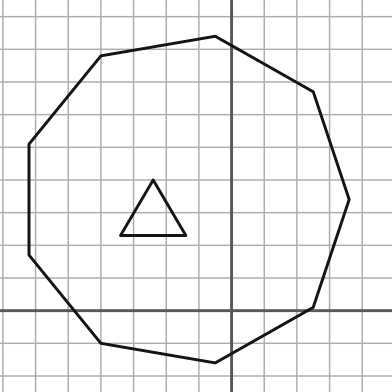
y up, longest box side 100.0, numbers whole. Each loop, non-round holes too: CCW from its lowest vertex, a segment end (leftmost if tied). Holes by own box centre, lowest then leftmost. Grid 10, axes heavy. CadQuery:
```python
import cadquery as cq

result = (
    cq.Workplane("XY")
    .moveTo(-5.0, -16.0)
    .lineTo(25.0, 1.0)
    .lineTo(36.0, 34.0)
    .lineTo(25.0, 67.0)
    .lineTo(-5.0, 84.0)
    .lineTo(-40.0, 78.0)
    .lineTo(-62.0, 51.0)
    .lineTo(-62.0, 17.0)
    .lineTo(-40.0, -10.0)
    .close()
    .moveTo(-34.0, 23.0)
    .lineTo(-14.0, 23.0)
    .lineTo(-24.0, 40.0)
    .close()
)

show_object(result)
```